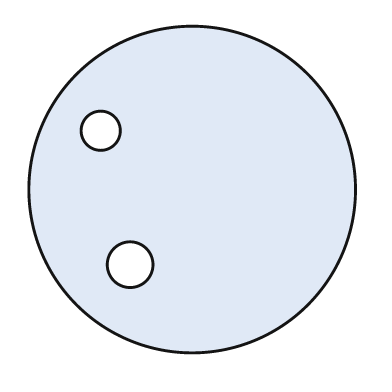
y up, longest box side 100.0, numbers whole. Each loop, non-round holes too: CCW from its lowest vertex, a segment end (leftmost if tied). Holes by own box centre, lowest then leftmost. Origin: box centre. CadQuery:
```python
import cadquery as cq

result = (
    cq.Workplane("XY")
    .moveTo(0.0, 0.0)
    .circle(50.0)
    .moveTo(-19.0, -23.0)
    .circle(7.0)
    .moveTo(-28.0, 18.0)
    .circle(6.0)
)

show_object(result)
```